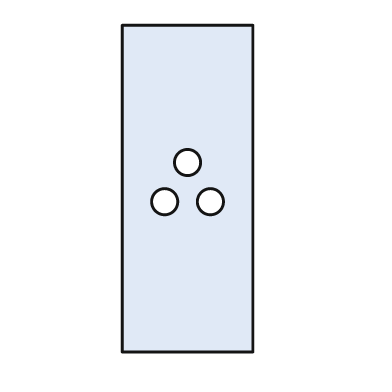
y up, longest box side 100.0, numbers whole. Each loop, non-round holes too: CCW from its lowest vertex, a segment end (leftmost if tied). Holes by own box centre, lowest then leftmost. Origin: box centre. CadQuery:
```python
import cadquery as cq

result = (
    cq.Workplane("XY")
    .moveTo(-20.0, -50.0)
    .lineTo(20.0, -50.0)
    .lineTo(20.0, 50.0)
    .lineTo(-20.0, 50.0)
    .close()
    .moveTo(-7.0, -4.0)
    .circle(4.0)
    .moveTo(7.0, -4.0)
    .circle(4.0)
    .moveTo(0.0, 8.0)
    .circle(4.0)
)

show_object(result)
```